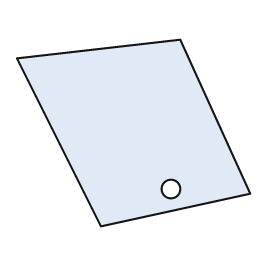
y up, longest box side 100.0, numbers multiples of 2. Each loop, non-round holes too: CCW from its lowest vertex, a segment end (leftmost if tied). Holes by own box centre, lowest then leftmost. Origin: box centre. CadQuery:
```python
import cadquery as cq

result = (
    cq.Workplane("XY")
    .moveTo(-14.0, -40.0)
    .lineTo(50.0, -26.0)
    .lineTo(20.0, 40.0)
    .lineTo(-50.0, 32.0)
    .close()
    .moveTo(16.0, -24.0)
    .circle(4.0)
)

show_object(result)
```